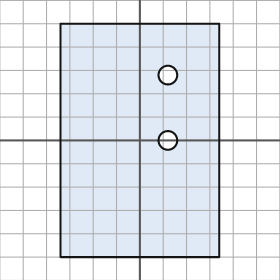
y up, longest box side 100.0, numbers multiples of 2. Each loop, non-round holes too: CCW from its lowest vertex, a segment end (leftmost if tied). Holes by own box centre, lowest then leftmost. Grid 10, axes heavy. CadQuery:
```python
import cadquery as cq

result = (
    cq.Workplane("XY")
    .moveTo(-34.0, -50.0)
    .lineTo(34.0, -50.0)
    .lineTo(34.0, 50.0)
    .lineTo(-34.0, 50.0)
    .close()
    .moveTo(12.0, 0.0)
    .circle(4.0)
    .moveTo(12.0, 28.0)
    .circle(4.0)
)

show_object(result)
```